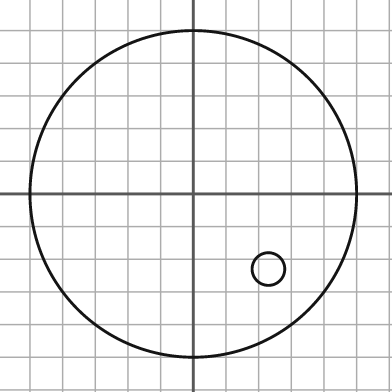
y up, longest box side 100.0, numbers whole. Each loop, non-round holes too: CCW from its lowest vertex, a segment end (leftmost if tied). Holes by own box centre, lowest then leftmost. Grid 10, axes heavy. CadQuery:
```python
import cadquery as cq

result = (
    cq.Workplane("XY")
    .moveTo(0.0, 0.0)
    .circle(50.0)
    .moveTo(23.0, -23.0)
    .circle(5.0)
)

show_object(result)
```